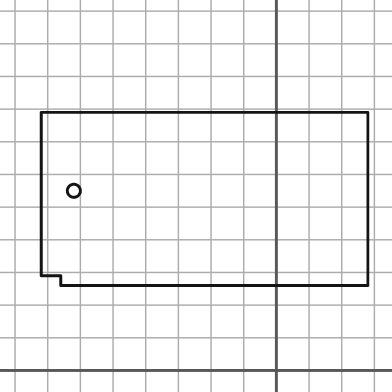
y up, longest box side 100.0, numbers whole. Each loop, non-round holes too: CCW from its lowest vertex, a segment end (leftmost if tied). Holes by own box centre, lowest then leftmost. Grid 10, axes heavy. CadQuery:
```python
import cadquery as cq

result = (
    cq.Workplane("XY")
    .moveTo(-66.0, 26.0)
    .lineTo(28.0, 26.0)
    .lineTo(28.0, 79.0)
    .lineTo(-72.0, 79.0)
    .lineTo(-72.0, 29.0)
    .lineTo(-66.0, 29.0)
    .close()
    .moveTo(-62.0, 55.0)
    .circle(2.0)
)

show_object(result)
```